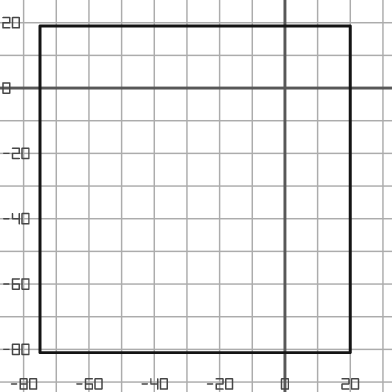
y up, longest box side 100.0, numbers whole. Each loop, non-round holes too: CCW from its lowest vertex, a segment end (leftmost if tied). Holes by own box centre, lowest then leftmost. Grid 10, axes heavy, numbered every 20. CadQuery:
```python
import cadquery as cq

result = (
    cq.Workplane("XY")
    .moveTo(-75.0, -81.0)
    .lineTo(20.0, -81.0)
    .lineTo(20.0, 19.0)
    .lineTo(-75.0, 19.0)
    .close()
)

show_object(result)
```